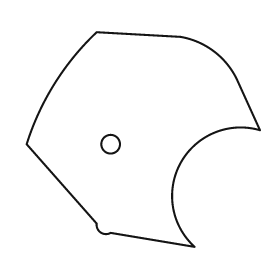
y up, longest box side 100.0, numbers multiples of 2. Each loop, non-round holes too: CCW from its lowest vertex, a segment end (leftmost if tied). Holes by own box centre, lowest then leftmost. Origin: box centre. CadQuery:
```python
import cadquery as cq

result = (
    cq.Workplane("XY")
    .moveTo(22.0, -46.0)
    .threePointArc((16.0, -10.0), (50.0, 4.0))
    .lineTo(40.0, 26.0)
    .threePointArc((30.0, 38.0), (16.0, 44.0))
    .lineTo(-20.0, 46.0)
    .threePointArc((-38.0, 24.0), (-50.0, -2.0))
    .lineTo(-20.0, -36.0)
    .threePointArc((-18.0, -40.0), (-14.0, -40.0))
    .close()
    .moveTo(-14.0, -2.0)
    .circle(4.0)
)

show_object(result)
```